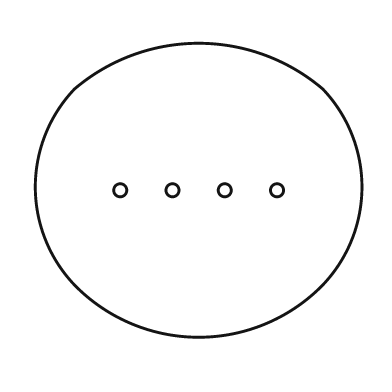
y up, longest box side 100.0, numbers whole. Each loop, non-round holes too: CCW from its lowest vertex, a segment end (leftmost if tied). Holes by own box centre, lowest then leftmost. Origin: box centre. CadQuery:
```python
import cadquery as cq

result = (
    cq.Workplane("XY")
    .moveTo(-38.0, -29.0)
    .threePointArc((0.0, -45.0), (38.0, -29.0))
    .threePointArc((50.0, 1.0), (38.0, 31.0))
    .threePointArc((0.0, 45.0), (-38.0, 31.0))
    .threePointArc((-50.0, 1.0), (-38.0, -29.0))
    .close()
    .moveTo(-24.0, 0.0)
    .circle(2.0)
    .moveTo(-8.0, 0.0)
    .circle(2.0)
    .moveTo(8.0, 0.0)
    .circle(2.0)
    .moveTo(24.0, 0.0)
    .circle(2.0)
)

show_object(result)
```